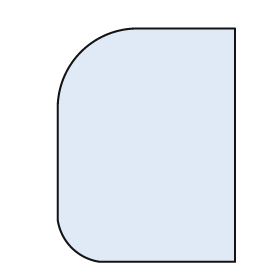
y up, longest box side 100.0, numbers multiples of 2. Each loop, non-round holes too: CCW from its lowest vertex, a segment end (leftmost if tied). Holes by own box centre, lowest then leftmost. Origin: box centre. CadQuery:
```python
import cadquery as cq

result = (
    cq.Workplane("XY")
    .moveTo(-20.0, -50.0)
    .lineTo(38.0, -50.0)
    .lineTo(38.0, 50.0)
    .lineTo(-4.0, 50.0)
    .threePointArc((-28.0, 40.0), (-38.0, 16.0))
    .lineTo(-38.0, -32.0)
    .threePointArc((-32.0, -44.0), (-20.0, -50.0))
    .close()
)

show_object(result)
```